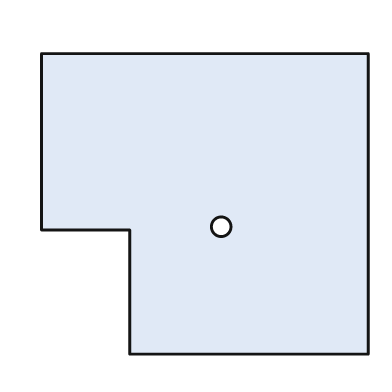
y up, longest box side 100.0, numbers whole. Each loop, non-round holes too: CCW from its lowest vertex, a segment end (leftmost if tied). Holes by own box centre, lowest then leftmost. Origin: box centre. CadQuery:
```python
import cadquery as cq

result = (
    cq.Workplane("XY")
    .moveTo(-23.0, -46.0)
    .lineTo(50.0, -46.0)
    .lineTo(50.0, 46.0)
    .lineTo(-50.0, 46.0)
    .lineTo(-50.0, -8.0)
    .lineTo(-23.0, -8.0)
    .close()
    .moveTo(5.0, -7.0)
    .circle(3.0)
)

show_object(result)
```